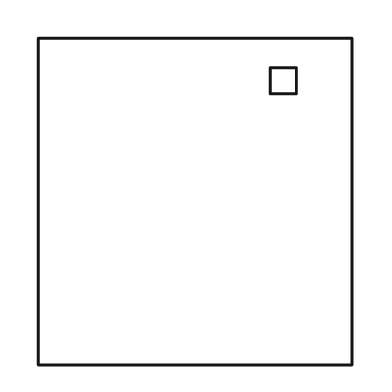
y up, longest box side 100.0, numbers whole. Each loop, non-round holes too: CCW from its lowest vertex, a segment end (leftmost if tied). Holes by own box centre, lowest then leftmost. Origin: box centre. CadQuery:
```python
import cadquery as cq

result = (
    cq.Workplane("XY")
    .moveTo(-48.0, -50.0)
    .lineTo(48.0, -50.0)
    .lineTo(48.0, 50.0)
    .lineTo(-48.0, 50.0)
    .close()
    .moveTo(23.0, 33.0)
    .lineTo(31.0, 33.0)
    .lineTo(31.0, 41.0)
    .lineTo(23.0, 41.0)
    .close()
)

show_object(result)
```